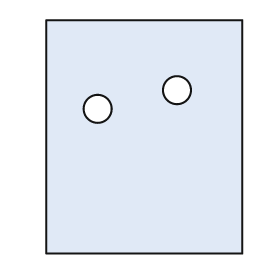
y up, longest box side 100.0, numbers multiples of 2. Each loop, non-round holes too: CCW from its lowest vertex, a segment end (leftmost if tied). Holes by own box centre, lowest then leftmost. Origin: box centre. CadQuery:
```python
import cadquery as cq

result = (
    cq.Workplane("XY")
    .moveTo(-42.0, -50.0)
    .lineTo(42.0, -50.0)
    .lineTo(42.0, 50.0)
    .lineTo(-42.0, 50.0)
    .close()
    .moveTo(-20.0, 12.0)
    .circle(6.0)
    .moveTo(14.0, 20.0)
    .circle(6.0)
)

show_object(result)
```